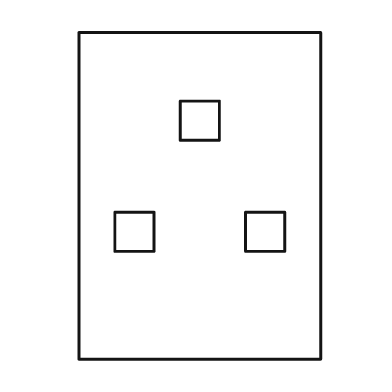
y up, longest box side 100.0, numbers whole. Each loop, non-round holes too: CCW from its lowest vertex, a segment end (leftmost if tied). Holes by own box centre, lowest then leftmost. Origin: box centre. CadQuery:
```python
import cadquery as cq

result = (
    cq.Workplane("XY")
    .moveTo(-37.0, -50.0)
    .lineTo(37.0, -50.0)
    .lineTo(37.0, 50.0)
    .lineTo(-37.0, 50.0)
    .close()
    .moveTo(-26.0, -17.0)
    .lineTo(-14.0, -17.0)
    .lineTo(-14.0, -5.0)
    .lineTo(-26.0, -5.0)
    .close()
    .moveTo(14.0, -17.0)
    .lineTo(26.0, -17.0)
    .lineTo(26.0, -5.0)
    .lineTo(14.0, -5.0)
    .close()
    .moveTo(-6.0, 17.0)
    .lineTo(6.0, 17.0)
    .lineTo(6.0, 29.0)
    .lineTo(-6.0, 29.0)
    .close()
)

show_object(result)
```